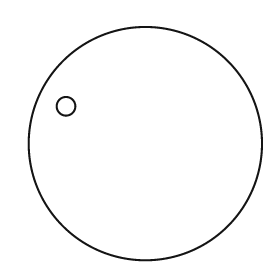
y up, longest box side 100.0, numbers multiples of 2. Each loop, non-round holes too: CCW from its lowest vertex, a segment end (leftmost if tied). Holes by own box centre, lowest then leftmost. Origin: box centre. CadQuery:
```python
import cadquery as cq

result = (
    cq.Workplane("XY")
    .moveTo(0.0, 0.0)
    .circle(50.0)
    .moveTo(-34.0, 16.0)
    .circle(4.0)
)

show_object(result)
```